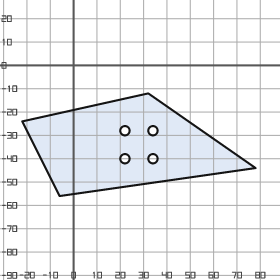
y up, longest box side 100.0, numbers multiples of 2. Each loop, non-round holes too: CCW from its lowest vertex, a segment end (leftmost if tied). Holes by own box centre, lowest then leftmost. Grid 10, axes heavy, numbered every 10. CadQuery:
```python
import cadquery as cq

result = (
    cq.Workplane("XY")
    .moveTo(-6.0, -56.0)
    .lineTo(78.0, -44.0)
    .lineTo(32.0, -12.0)
    .lineTo(-22.0, -24.0)
    .close()
    .moveTo(22.0, -40.0)
    .circle(2.0)
    .moveTo(34.0, -40.0)
    .circle(2.0)
    .moveTo(22.0, -28.0)
    .circle(2.0)
    .moveTo(34.0, -28.0)
    .circle(2.0)
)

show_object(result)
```